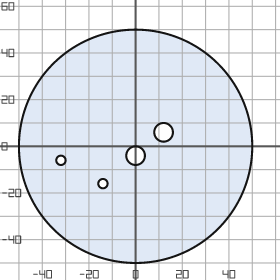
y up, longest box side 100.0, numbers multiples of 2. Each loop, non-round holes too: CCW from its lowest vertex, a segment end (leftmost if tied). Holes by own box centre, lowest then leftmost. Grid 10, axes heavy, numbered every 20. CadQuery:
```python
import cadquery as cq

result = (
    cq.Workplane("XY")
    .moveTo(0.0, 0.0)
    .circle(50.0)
    .moveTo(-14.0, -16.0)
    .circle(2.0)
    .moveTo(-32.0, -6.0)
    .circle(2.0)
    .moveTo(0.0, -4.0)
    .circle(4.0)
    .moveTo(12.0, 6.0)
    .circle(4.0)
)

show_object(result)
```